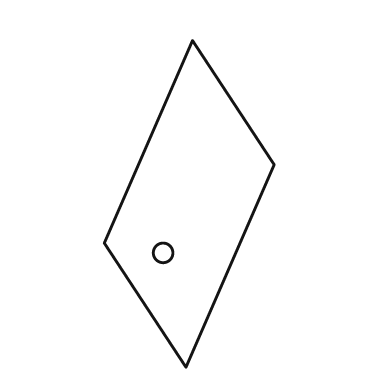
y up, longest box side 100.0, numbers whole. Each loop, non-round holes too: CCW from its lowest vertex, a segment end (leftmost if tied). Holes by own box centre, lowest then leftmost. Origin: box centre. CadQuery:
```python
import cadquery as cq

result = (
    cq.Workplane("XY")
    .moveTo(-1.0, -50.0)
    .lineTo(26.0, 12.0)
    .lineTo(1.0, 50.0)
    .lineTo(-26.0, -12.0)
    .close()
    .moveTo(-8.0, -15.0)
    .circle(3.0)
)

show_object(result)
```